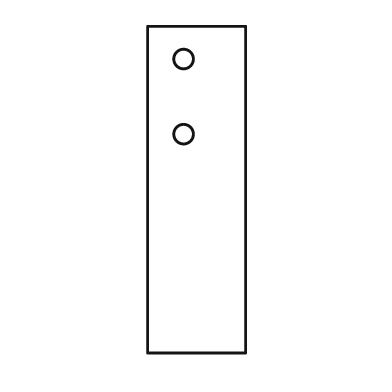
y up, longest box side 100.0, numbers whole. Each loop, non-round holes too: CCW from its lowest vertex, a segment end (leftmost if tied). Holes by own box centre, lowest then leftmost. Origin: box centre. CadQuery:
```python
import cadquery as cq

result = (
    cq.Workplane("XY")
    .moveTo(-15.0, -50.0)
    .lineTo(15.0, -50.0)
    .lineTo(15.0, 50.0)
    .lineTo(-15.0, 50.0)
    .close()
    .moveTo(-4.0, 17.0)
    .circle(3.0)
    .moveTo(-4.0, 40.0)
    .circle(3.0)
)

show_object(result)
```